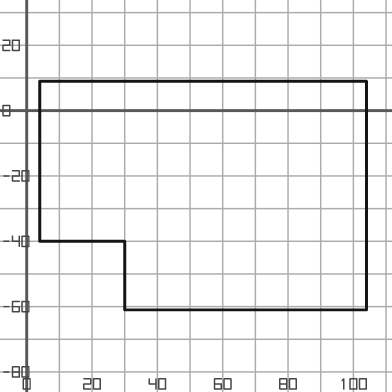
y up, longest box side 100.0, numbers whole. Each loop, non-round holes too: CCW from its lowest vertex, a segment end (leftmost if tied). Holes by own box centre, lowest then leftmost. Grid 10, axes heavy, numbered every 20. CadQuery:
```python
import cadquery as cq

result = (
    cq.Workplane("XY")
    .moveTo(30.0, -61.0)
    .lineTo(104.0, -61.0)
    .lineTo(104.0, 9.0)
    .lineTo(4.0, 9.0)
    .lineTo(4.0, -40.0)
    .lineTo(30.0, -40.0)
    .close()
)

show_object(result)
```